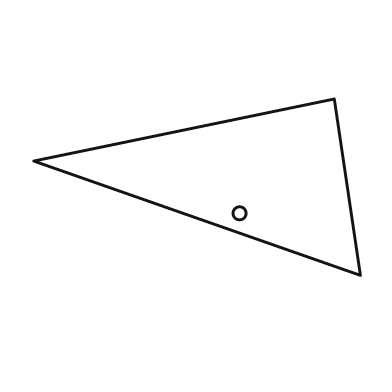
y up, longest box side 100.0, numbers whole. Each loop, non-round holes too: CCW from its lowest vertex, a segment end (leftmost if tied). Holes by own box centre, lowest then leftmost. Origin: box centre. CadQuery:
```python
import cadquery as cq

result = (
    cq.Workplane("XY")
    .moveTo(50.0, -27.0)
    .lineTo(42.0, 27.0)
    .lineTo(-50.0, 8.0)
    .close()
    .moveTo(13.0, -8.0)
    .circle(2.0)
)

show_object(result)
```